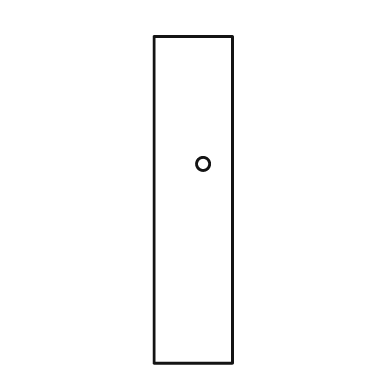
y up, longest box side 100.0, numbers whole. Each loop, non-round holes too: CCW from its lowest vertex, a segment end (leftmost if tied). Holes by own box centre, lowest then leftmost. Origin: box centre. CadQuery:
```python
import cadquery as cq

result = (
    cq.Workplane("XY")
    .moveTo(-12.0, -50.0)
    .lineTo(12.0, -50.0)
    .lineTo(12.0, 50.0)
    .lineTo(-12.0, 50.0)
    .close()
    .moveTo(3.0, 11.0)
    .circle(2.0)
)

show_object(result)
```